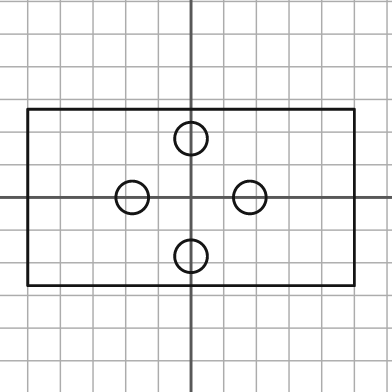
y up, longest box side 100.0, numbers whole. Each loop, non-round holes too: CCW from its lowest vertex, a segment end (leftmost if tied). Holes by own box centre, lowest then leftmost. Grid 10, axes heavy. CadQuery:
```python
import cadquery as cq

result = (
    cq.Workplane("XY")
    .moveTo(-50.0, -27.0)
    .lineTo(50.0, -27.0)
    .lineTo(50.0, 27.0)
    .lineTo(-50.0, 27.0)
    .close()
    .moveTo(0.0, -18.0)
    .circle(5.0)
    .moveTo(-18.0, 0.0)
    .circle(5.0)
    .moveTo(18.0, 0.0)
    .circle(5.0)
    .moveTo(0.0, 18.0)
    .circle(5.0)
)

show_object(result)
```